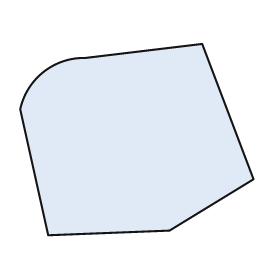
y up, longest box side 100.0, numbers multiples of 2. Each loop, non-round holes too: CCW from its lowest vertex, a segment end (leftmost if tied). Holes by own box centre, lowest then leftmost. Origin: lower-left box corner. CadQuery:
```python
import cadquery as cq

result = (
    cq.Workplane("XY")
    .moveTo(12.0, 0.0)
    .lineTo(64.0, 2.0)
    .lineTo(100.0, 24.0)
    .lineTo(78.0, 82.0)
    .lineTo(28.0, 76.0)
    .threePointArc((10.0, 70.0), (0.0, 54.0))
    .close()
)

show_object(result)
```